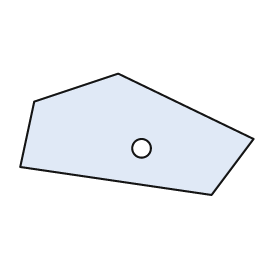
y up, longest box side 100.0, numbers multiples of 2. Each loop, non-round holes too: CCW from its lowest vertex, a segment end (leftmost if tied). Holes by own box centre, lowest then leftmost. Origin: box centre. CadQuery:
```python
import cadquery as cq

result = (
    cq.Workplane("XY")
    .moveTo(32.0, -26.0)
    .lineTo(50.0, -2.0)
    .lineTo(-8.0, 26.0)
    .lineTo(-44.0, 14.0)
    .lineTo(-50.0, -14.0)
    .close()
    .moveTo(2.0, -6.0)
    .circle(4.0)
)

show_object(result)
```